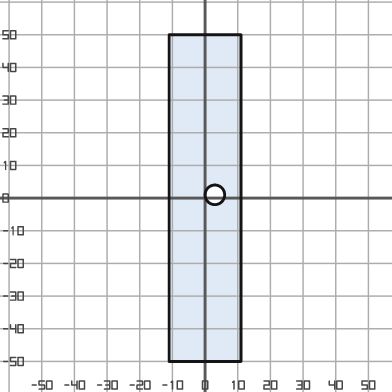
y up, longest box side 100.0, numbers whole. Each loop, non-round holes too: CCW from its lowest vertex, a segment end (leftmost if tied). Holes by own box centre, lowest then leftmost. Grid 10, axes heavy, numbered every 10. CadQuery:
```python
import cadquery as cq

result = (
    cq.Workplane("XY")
    .moveTo(-11.0, -50.0)
    .lineTo(11.0, -50.0)
    .lineTo(11.0, 50.0)
    .lineTo(-11.0, 50.0)
    .close()
    .moveTo(3.0, 1.0)
    .circle(3.0)
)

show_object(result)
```